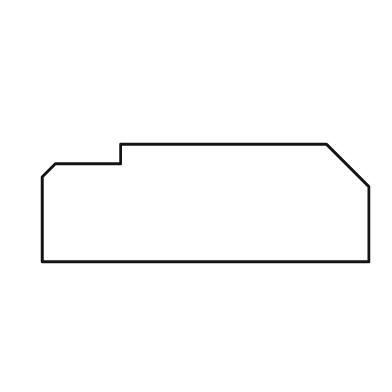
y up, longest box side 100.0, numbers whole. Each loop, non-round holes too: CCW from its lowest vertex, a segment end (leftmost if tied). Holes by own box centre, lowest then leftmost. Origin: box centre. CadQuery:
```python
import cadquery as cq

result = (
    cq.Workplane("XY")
    .moveTo(-50.0, -18.0)
    .lineTo(50.0, -18.0)
    .lineTo(50.0, 5.0)
    .lineTo(37.0, 18.0)
    .lineTo(-26.0, 18.0)
    .lineTo(-26.0, 12.0)
    .lineTo(-46.0, 12.0)
    .lineTo(-50.0, 8.0)
    .close()
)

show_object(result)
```